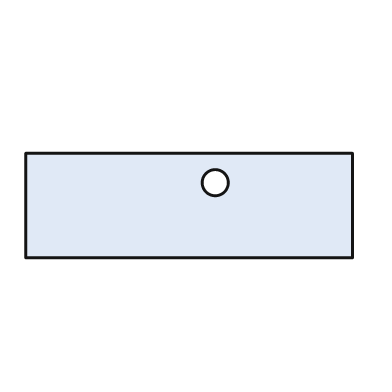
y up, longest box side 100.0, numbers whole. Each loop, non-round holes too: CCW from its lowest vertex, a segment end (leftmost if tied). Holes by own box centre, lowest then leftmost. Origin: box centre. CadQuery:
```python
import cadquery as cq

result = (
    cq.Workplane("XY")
    .moveTo(-50.0, -16.0)
    .lineTo(50.0, -16.0)
    .lineTo(50.0, 16.0)
    .lineTo(-50.0, 16.0)
    .close()
    .moveTo(8.0, 7.0)
    .circle(4.0)
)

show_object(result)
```